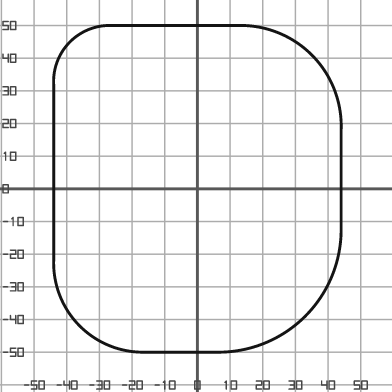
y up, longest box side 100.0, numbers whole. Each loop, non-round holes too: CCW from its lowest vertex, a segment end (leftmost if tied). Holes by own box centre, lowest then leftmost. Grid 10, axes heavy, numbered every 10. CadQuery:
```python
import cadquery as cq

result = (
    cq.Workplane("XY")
    .moveTo(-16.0, -50.0)
    .lineTo(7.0, -50.0)
    .threePointArc((33.0, -39.0), (44.0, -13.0))
    .lineTo(44.0, 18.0)
    .threePointArc((35.0, 41.0), (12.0, 50.0))
    .lineTo(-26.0, 50.0)
    .threePointArc((-39.0, 45.0), (-44.0, 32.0))
    .lineTo(-44.0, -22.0)
    .threePointArc((-36.0, -42.0), (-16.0, -50.0))
    .close()
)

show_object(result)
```